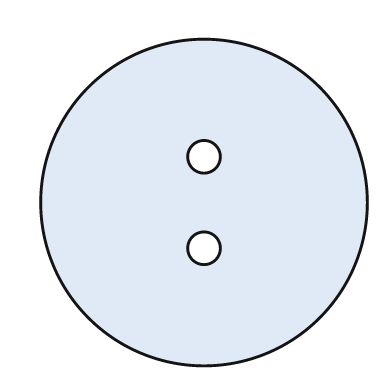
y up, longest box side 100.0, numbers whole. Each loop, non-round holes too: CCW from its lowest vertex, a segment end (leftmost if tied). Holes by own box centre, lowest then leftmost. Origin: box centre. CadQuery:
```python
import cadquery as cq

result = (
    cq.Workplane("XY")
    .moveTo(0.0, 0.0)
    .circle(50.0)
    .moveTo(0.0, -14.0)
    .circle(5.0)
    .moveTo(0.0, 14.0)
    .circle(5.0)
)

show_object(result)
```